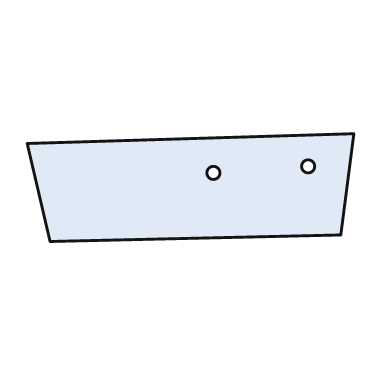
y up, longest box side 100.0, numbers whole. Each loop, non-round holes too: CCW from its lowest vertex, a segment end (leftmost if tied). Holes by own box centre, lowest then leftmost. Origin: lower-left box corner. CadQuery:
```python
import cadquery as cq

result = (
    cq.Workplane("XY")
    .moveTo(7.0, 0.0)
    .lineTo(96.0, 2.0)
    .lineTo(100.0, 33.0)
    .lineTo(0.0, 30.0)
    .close()
    .moveTo(57.0, 21.0)
    .circle(2.0)
    .moveTo(86.0, 23.0)
    .circle(2.0)
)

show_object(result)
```